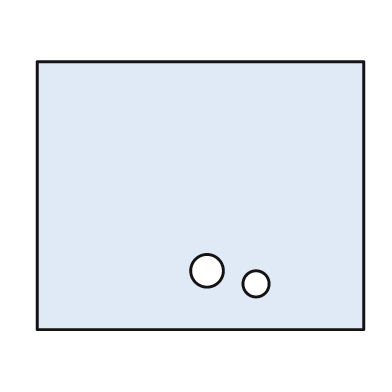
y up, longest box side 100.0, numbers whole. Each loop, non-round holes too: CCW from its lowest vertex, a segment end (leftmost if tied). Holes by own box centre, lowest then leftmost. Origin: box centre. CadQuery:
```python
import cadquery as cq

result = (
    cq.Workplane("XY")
    .moveTo(-50.0, -41.0)
    .lineTo(50.0, -41.0)
    .lineTo(50.0, 41.0)
    .lineTo(-50.0, 41.0)
    .close()
    .moveTo(17.0, -27.0)
    .circle(4.0)
    .moveTo(2.0, -23.0)
    .circle(5.0)
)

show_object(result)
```